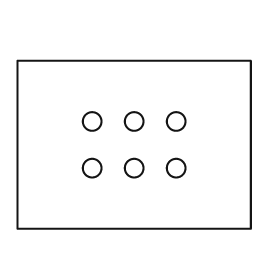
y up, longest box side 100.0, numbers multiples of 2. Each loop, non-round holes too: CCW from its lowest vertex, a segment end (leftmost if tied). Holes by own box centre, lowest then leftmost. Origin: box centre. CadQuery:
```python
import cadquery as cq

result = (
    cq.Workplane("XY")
    .moveTo(-50.0, -36.0)
    .lineTo(50.0, -36.0)
    .lineTo(50.0, 36.0)
    .lineTo(-50.0, 36.0)
    .close()
    .moveTo(-18.0, -10.0)
    .circle(4.0)
    .moveTo(0.0, -10.0)
    .circle(4.0)
    .moveTo(18.0, -10.0)
    .circle(4.0)
    .moveTo(-18.0, 10.0)
    .circle(4.0)
    .moveTo(0.0, 10.0)
    .circle(4.0)
    .moveTo(18.0, 10.0)
    .circle(4.0)
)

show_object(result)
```